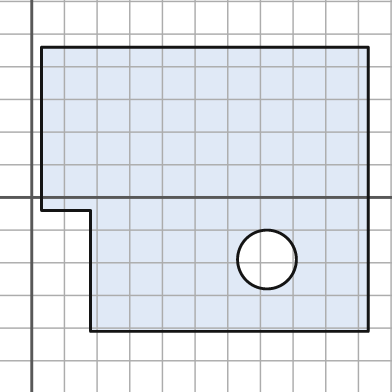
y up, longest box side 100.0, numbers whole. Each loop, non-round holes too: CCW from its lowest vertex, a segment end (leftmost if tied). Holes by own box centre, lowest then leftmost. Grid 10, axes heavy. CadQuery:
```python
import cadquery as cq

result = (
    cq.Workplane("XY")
    .moveTo(18.0, -41.0)
    .lineTo(103.0, -41.0)
    .lineTo(103.0, 46.0)
    .lineTo(3.0, 46.0)
    .lineTo(3.0, -4.0)
    .lineTo(18.0, -4.0)
    .close()
    .moveTo(72.0, -19.0)
    .circle(9.0)
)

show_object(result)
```